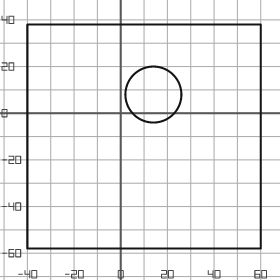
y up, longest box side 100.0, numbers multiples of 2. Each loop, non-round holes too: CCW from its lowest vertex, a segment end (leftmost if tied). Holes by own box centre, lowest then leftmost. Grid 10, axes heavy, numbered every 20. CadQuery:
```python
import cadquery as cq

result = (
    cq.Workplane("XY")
    .moveTo(-40.0, -58.0)
    .lineTo(60.0, -58.0)
    .lineTo(60.0, 38.0)
    .lineTo(-40.0, 38.0)
    .close()
    .moveTo(14.0, 8.0)
    .circle(12.0)
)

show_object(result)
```